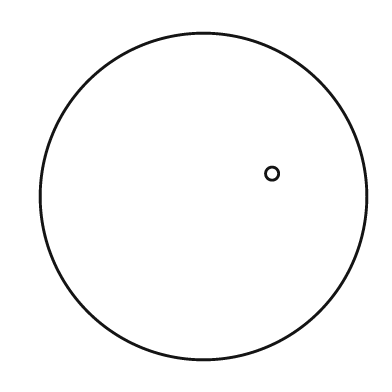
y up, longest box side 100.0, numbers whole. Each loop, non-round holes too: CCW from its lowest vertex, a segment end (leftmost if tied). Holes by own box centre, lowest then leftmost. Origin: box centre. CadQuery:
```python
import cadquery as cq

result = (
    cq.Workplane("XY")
    .moveTo(0.0, 0.0)
    .circle(50.0)
    .moveTo(21.0, 7.0)
    .circle(2.0)
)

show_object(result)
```